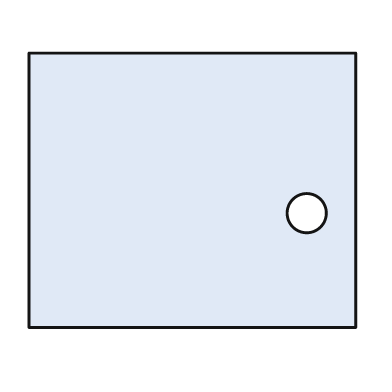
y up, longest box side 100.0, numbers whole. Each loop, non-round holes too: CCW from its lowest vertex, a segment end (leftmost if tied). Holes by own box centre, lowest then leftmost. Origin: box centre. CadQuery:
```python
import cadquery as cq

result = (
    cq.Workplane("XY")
    .moveTo(-50.0, -42.0)
    .lineTo(50.0, -42.0)
    .lineTo(50.0, 42.0)
    .lineTo(-50.0, 42.0)
    .close()
    .moveTo(35.0, -7.0)
    .circle(6.0)
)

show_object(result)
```